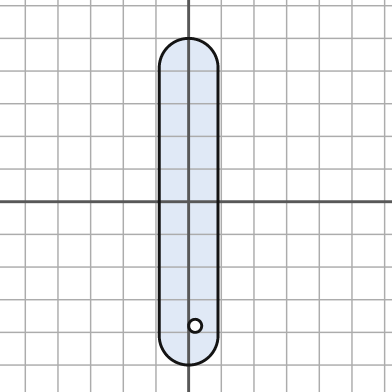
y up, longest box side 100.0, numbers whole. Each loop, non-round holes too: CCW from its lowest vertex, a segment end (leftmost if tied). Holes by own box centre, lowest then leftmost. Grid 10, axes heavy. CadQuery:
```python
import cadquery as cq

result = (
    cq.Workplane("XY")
    .moveTo(-9.0, -41.0)
    .threePointArc((0.0, -50.0), (9.0, -41.0))
    .lineTo(9.0, 41.0)
    .threePointArc((0.0, 50.0), (-9.0, 41.0))
    .close()
    .moveTo(2.0, -38.0)
    .circle(2.0)
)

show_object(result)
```